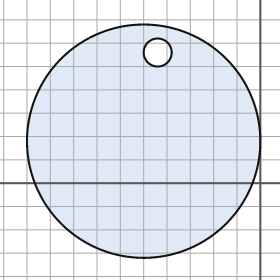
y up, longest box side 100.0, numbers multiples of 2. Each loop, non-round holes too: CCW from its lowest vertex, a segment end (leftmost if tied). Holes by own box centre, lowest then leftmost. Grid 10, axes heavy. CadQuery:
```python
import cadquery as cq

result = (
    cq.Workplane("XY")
    .moveTo(-50.0, 18.0)
    .circle(50.0)
    .moveTo(-44.0, 56.0)
    .circle(6.0)
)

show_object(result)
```